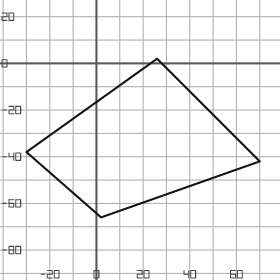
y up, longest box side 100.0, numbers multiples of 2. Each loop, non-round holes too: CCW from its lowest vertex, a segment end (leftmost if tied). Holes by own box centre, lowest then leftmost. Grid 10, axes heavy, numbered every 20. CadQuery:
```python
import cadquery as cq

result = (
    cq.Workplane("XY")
    .moveTo(2.0, -66.0)
    .lineTo(70.0, -42.0)
    .lineTo(26.0, 2.0)
    .lineTo(-30.0, -38.0)
    .close()
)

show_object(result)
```